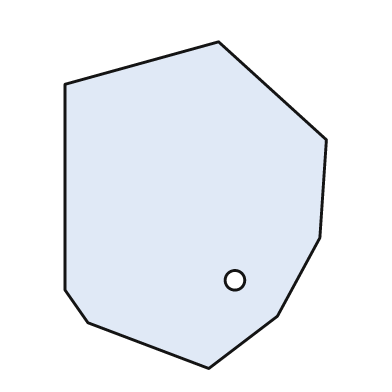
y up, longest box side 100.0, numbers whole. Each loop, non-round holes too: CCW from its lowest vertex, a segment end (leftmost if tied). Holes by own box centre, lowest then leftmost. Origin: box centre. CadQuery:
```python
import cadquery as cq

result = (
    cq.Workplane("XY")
    .moveTo(4.0, -50.0)
    .lineTo(25.0, -34.0)
    .lineTo(38.0, -10.0)
    .lineTo(40.0, 20.0)
    .lineTo(7.0, 50.0)
    .lineTo(-40.0, 37.0)
    .lineTo(-40.0, -26.0)
    .lineTo(-33.0, -36.0)
    .close()
    .moveTo(12.0, -23.0)
    .circle(3.0)
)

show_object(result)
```